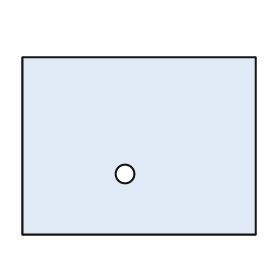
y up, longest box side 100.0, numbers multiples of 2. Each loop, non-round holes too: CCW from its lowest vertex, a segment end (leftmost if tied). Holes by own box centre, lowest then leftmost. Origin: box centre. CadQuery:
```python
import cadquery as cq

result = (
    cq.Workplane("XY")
    .moveTo(-50.0, -38.0)
    .lineTo(50.0, -38.0)
    .lineTo(50.0, 38.0)
    .lineTo(-50.0, 38.0)
    .close()
    .moveTo(-6.0, -12.0)
    .circle(4.0)
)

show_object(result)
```